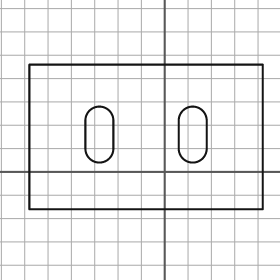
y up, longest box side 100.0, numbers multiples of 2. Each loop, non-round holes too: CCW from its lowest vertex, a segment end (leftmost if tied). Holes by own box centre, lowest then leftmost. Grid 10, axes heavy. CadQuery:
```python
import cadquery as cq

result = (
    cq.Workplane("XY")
    .moveTo(-58.0, -16.0)
    .lineTo(42.0, -16.0)
    .lineTo(42.0, 46.0)
    .lineTo(-58.0, 46.0)
    .close()
    .moveTo(-34.0, 10.0)
    .threePointArc((-28.0, 4.0), (-22.0, 10.0))
    .lineTo(-22.0, 22.0)
    .threePointArc((-28.0, 28.0), (-34.0, 22.0))
    .close()
    .moveTo(6.0, 10.0)
    .threePointArc((12.0, 4.0), (18.0, 10.0))
    .lineTo(18.0, 22.0)
    .threePointArc((12.0, 28.0), (6.0, 22.0))
    .close()
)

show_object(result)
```